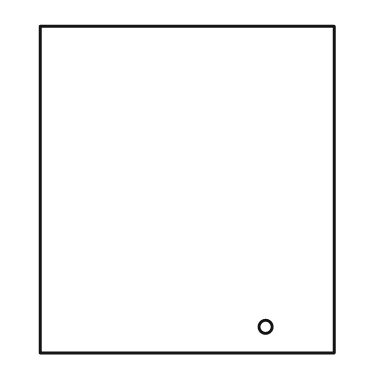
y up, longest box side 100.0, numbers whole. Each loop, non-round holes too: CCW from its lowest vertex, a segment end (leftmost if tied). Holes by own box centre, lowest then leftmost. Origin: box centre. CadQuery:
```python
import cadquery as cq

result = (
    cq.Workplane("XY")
    .moveTo(-45.0, -50.0)
    .lineTo(45.0, -50.0)
    .lineTo(45.0, 50.0)
    .lineTo(-45.0, 50.0)
    .close()
    .moveTo(24.0, -42.0)
    .circle(2.0)
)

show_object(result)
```